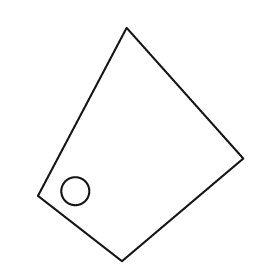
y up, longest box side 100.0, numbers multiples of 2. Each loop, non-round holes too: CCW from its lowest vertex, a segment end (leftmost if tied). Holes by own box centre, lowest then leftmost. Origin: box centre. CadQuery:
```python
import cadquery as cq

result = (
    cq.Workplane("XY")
    .moveTo(-8.0, -50.0)
    .lineTo(44.0, -6.0)
    .lineTo(-6.0, 50.0)
    .lineTo(-44.0, -22.0)
    .close()
    .moveTo(-28.0, -20.0)
    .circle(6.0)
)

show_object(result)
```